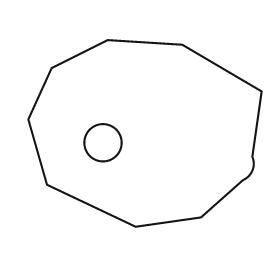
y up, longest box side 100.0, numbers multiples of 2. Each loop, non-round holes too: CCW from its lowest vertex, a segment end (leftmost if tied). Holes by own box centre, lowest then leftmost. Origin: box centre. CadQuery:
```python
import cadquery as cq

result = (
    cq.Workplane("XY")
    .moveTo(-4.0, -40.0)
    .lineTo(24.0, -36.0)
    .lineTo(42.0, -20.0)
    .threePointArc((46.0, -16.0), (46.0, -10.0))
    .lineTo(50.0, 18.0)
    .lineTo(16.0, 38.0)
    .lineTo(-16.0, 40.0)
    .lineTo(-40.0, 28.0)
    .lineTo(-50.0, 6.0)
    .lineTo(-42.0, -22.0)
    .close()
    .moveTo(-18.0, -4.0)
    .circle(8.0)
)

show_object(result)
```